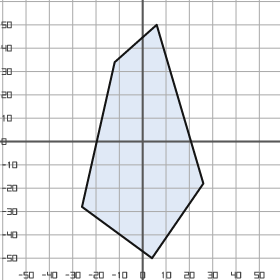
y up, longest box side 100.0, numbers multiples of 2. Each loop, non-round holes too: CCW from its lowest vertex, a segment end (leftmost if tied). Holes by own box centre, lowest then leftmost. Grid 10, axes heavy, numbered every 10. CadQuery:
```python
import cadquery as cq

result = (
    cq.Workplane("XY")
    .moveTo(4.0, -50.0)
    .lineTo(26.0, -18.0)
    .lineTo(6.0, 50.0)
    .lineTo(-12.0, 34.0)
    .lineTo(-26.0, -28.0)
    .close()
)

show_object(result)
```